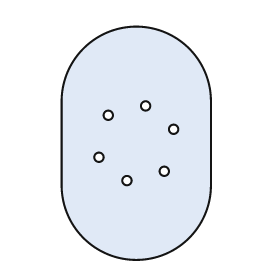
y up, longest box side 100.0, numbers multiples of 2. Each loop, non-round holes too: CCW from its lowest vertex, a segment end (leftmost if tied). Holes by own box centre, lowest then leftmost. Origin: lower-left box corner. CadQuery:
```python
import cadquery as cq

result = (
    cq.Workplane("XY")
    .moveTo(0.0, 32.0)
    .threePointArc((32.0, 0.0), (64.0, 32.0))
    .lineTo(64.0, 68.0)
    .threePointArc((32.0, 100.0), (0.0, 68.0))
    .close()
    .moveTo(28.0, 34.0)
    .circle(2.0)
    .moveTo(44.0, 38.0)
    .circle(2.0)
    .moveTo(16.0, 44.0)
    .circle(2.0)
    .moveTo(48.0, 56.0)
    .circle(2.0)
    .moveTo(20.0, 62.0)
    .circle(2.0)
    .moveTo(36.0, 66.0)
    .circle(2.0)
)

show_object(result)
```